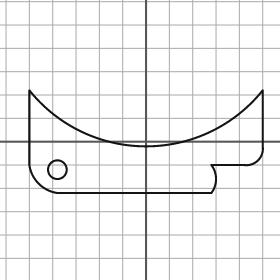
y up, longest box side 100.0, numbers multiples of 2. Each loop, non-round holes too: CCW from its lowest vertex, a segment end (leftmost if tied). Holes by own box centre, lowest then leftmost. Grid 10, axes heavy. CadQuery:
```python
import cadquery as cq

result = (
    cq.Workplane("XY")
    .moveTo(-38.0, -22.0)
    .lineTo(28.0, -22.0)
    .threePointArc((30.0, -16.0), (28.0, -10.0))
    .lineTo(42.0, -10.0)
    .threePointArc((48.0, -8.0), (50.0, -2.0))
    .lineTo(50.0, 22.0)
    .threePointArc((0.0, -2.0), (-50.0, 22.0))
    .lineTo(-50.0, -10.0)
    .threePointArc((-46.0, -18.0), (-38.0, -22.0))
    .close()
    .moveTo(-38.0, -12.0)
    .circle(4.0)
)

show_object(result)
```